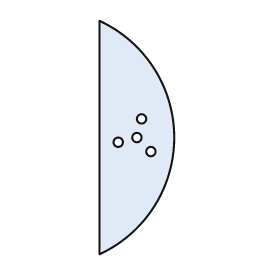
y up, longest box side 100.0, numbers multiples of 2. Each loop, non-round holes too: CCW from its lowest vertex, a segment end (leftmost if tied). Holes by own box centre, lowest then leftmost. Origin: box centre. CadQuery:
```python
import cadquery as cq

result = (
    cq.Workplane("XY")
    .moveTo(-16.0, -50.0)
    .threePointArc((16.0, 0.0), (-16.0, 50.0))
    .close()
    .moveTo(6.0, -6.0)
    .circle(2.0)
    .moveTo(-8.0, -2.0)
    .circle(2.0)
    .moveTo(0.0, 0.0)
    .circle(2.0)
    .moveTo(2.0, 8.0)
    .circle(2.0)
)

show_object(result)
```